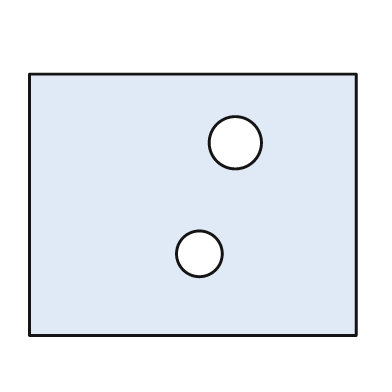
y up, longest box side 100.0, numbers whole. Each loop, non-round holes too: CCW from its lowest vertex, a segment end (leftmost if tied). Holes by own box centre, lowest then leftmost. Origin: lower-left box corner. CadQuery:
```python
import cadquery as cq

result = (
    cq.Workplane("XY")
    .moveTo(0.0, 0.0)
    .lineTo(100.0, 0.0)
    .lineTo(100.0, 80.0)
    .lineTo(0.0, 80.0)
    .close()
    .moveTo(52.0, 25.0)
    .circle(7.0)
    .moveTo(63.0, 59.0)
    .circle(8.0)
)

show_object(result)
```